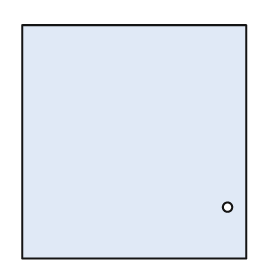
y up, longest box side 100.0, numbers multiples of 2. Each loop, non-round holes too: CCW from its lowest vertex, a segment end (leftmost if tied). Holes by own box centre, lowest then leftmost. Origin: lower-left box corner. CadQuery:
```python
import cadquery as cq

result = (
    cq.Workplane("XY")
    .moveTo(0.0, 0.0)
    .lineTo(96.0, 0.0)
    .lineTo(96.0, 100.0)
    .lineTo(0.0, 100.0)
    .close()
    .moveTo(88.0, 22.0)
    .circle(2.0)
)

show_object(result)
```